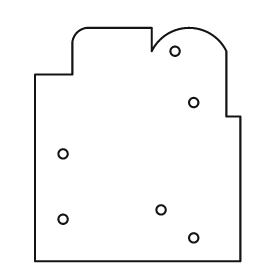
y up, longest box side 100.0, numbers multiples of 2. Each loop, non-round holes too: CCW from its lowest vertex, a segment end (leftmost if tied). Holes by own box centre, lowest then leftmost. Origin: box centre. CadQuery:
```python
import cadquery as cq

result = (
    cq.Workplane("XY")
    .moveTo(-44.0, -50.0)
    .lineTo(44.0, -50.0)
    .lineTo(44.0, 12.0)
    .lineTo(38.0, 12.0)
    .lineTo(38.0, 40.0)
    .threePointArc((22.0, 50.0), (6.0, 40.0))
    .lineTo(6.0, 50.0)
    .lineTo(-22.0, 50.0)
    .threePointArc((-26.0, 48.0), (-28.0, 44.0))
    .lineTo(-28.0, 30.0)
    .lineTo(-44.0, 30.0)
    .close()
    .moveTo(24.0, -40.0)
    .circle(2.0)
    .moveTo(-32.0, -32.0)
    .circle(2.0)
    .moveTo(10.0, -28.0)
    .circle(2.0)
    .moveTo(-32.0, -4.0)
    .circle(2.0)
    .moveTo(24.0, 18.0)
    .circle(2.0)
    .moveTo(16.0, 40.0)
    .circle(2.0)
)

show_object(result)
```